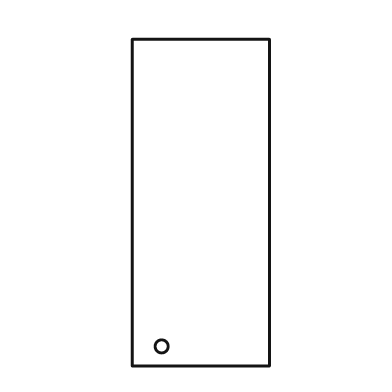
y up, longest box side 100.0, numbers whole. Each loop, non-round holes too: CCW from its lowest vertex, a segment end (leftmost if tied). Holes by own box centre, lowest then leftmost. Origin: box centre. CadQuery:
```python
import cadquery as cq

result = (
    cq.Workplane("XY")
    .moveTo(-21.0, -50.0)
    .lineTo(21.0, -50.0)
    .lineTo(21.0, 50.0)
    .lineTo(-21.0, 50.0)
    .close()
    .moveTo(-12.0, -44.0)
    .circle(2.0)
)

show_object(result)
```